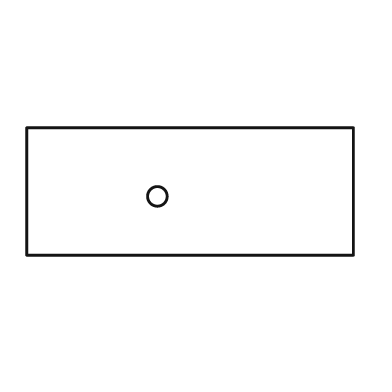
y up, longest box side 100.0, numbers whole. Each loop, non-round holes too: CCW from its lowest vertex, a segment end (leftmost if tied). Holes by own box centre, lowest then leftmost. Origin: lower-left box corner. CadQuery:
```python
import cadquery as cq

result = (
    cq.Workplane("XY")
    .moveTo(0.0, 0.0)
    .lineTo(100.0, 0.0)
    .lineTo(100.0, 39.0)
    .lineTo(0.0, 39.0)
    .close()
    .moveTo(40.0, 18.0)
    .circle(3.0)
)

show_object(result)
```